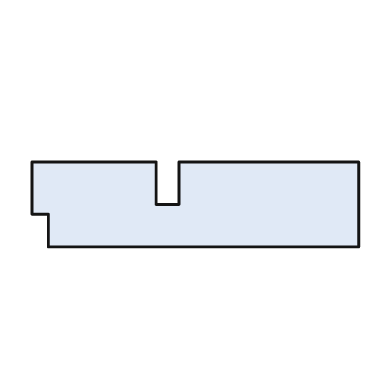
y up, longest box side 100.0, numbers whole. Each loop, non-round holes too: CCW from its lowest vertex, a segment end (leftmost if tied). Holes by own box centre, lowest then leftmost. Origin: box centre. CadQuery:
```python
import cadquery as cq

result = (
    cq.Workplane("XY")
    .moveTo(-45.0, -13.0)
    .lineTo(50.0, -13.0)
    .lineTo(50.0, 13.0)
    .lineTo(-5.0, 13.0)
    .lineTo(-5.0, 0.0)
    .lineTo(-12.0, 0.0)
    .lineTo(-12.0, 13.0)
    .lineTo(-50.0, 13.0)
    .lineTo(-50.0, -3.0)
    .lineTo(-45.0, -3.0)
    .close()
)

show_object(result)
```